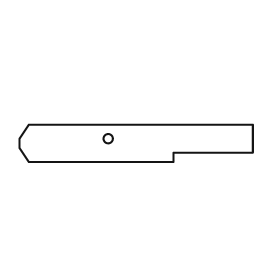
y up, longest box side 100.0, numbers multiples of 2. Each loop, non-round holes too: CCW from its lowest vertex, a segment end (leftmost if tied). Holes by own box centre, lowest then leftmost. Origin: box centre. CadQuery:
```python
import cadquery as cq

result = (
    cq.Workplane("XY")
    .moveTo(-46.0, -8.0)
    .lineTo(16.0, -8.0)
    .lineTo(16.0, -4.0)
    .lineTo(50.0, -4.0)
    .lineTo(50.0, 8.0)
    .lineTo(-46.0, 8.0)
    .lineTo(-50.0, 2.0)
    .lineTo(-50.0, -2.0)
    .close()
    .moveTo(-12.0, 2.0)
    .circle(2.0)
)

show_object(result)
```